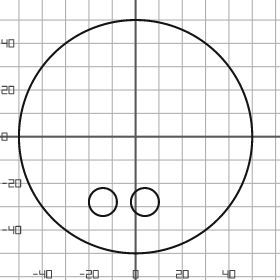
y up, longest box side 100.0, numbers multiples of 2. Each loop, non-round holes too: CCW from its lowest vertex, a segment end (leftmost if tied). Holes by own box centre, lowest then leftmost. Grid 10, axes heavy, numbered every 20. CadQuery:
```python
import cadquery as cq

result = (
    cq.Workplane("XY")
    .moveTo(0.0, 0.0)
    .circle(50.0)
    .moveTo(-14.0, -28.0)
    .circle(6.0)
    .moveTo(4.0, -28.0)
    .circle(6.0)
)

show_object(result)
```